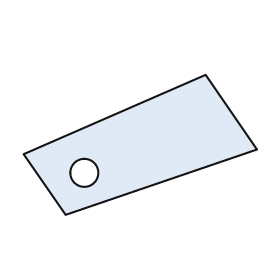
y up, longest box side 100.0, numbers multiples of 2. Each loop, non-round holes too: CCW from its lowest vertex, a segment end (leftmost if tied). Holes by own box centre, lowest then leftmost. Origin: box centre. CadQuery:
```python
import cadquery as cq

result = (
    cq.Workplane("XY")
    .moveTo(-32.0, -30.0)
    .lineTo(50.0, -2.0)
    .lineTo(28.0, 30.0)
    .lineTo(-50.0, -4.0)
    .close()
    .moveTo(-24.0, -12.0)
    .circle(6.0)
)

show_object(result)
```